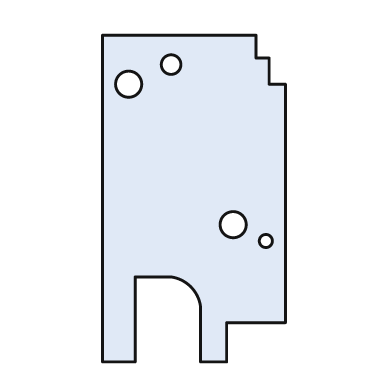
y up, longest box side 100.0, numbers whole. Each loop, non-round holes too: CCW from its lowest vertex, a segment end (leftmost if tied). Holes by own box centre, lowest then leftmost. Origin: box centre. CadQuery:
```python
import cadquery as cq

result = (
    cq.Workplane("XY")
    .moveTo(-28.0, -50.0)
    .lineTo(-18.0, -50.0)
    .lineTo(-18.0, -24.0)
    .lineTo(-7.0, -24.0)
    .threePointArc((-1.0, -27.0), (2.0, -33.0))
    .lineTo(2.0, -50.0)
    .lineTo(10.0, -50.0)
    .lineTo(10.0, -38.0)
    .lineTo(28.0, -38.0)
    .lineTo(28.0, 35.0)
    .lineTo(23.0, 35.0)
    .lineTo(23.0, 43.0)
    .lineTo(19.0, 43.0)
    .lineTo(19.0, 50.0)
    .lineTo(-28.0, 50.0)
    .close()
    .moveTo(22.0, -13.0)
    .circle(2.0)
    .moveTo(12.0, -8.0)
    .circle(4.0)
    .moveTo(-20.0, 35.0)
    .circle(4.0)
    .moveTo(-7.0, 41.0)
    .circle(3.0)
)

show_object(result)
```